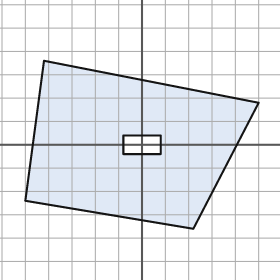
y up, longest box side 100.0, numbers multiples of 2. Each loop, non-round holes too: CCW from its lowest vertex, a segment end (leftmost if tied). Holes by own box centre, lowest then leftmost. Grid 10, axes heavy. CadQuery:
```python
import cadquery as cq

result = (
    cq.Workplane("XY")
    .moveTo(22.0, -36.0)
    .lineTo(50.0, 18.0)
    .lineTo(-42.0, 36.0)
    .lineTo(-50.0, -24.0)
    .close()
    .moveTo(-8.0, -4.0)
    .lineTo(8.0, -4.0)
    .lineTo(8.0, 4.0)
    .lineTo(-8.0, 4.0)
    .close()
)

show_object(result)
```